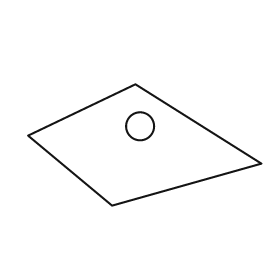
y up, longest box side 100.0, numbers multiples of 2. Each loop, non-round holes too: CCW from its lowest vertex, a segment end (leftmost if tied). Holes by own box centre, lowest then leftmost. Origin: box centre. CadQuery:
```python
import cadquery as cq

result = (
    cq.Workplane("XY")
    .moveTo(-14.0, -26.0)
    .lineTo(50.0, -8.0)
    .lineTo(-4.0, 26.0)
    .lineTo(-50.0, 4.0)
    .close()
    .moveTo(-2.0, 8.0)
    .circle(6.0)
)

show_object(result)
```